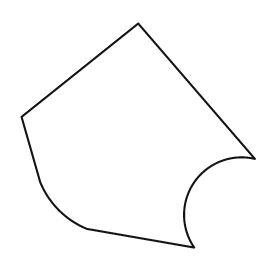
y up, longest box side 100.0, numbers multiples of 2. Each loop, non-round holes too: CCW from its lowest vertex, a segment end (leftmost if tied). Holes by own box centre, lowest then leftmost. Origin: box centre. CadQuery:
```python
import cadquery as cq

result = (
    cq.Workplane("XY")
    .moveTo(24.0, -48.0)
    .threePointArc((24.0, -20.0), (50.0, -10.0))
    .lineTo(0.0, 48.0)
    .lineTo(-50.0, 8.0)
    .lineTo(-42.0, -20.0)
    .threePointArc((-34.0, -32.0), (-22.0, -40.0))
    .close()
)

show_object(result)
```